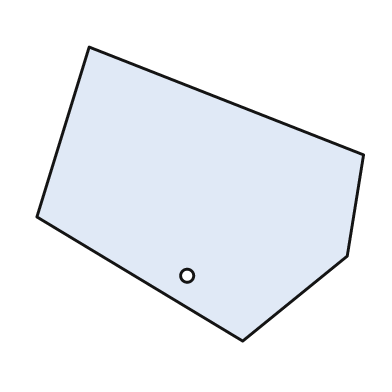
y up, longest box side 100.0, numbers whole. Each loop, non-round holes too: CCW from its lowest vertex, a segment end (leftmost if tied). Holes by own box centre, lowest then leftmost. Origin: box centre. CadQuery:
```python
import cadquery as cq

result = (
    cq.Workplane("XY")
    .moveTo(13.0, -45.0)
    .lineTo(45.0, -19.0)
    .lineTo(50.0, 12.0)
    .lineTo(-34.0, 45.0)
    .lineTo(-50.0, -7.0)
    .close()
    .moveTo(-4.0, -25.0)
    .circle(2.0)
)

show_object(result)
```